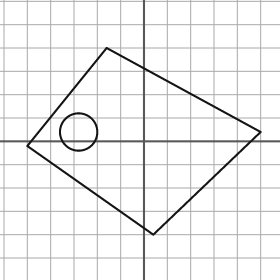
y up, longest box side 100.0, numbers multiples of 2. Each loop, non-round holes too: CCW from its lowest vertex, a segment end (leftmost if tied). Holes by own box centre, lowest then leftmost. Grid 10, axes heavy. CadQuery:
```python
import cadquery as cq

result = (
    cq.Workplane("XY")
    .moveTo(4.0, -40.0)
    .lineTo(50.0, 4.0)
    .lineTo(-16.0, 40.0)
    .lineTo(-50.0, -2.0)
    .close()
    .moveTo(-28.0, 4.0)
    .circle(8.0)
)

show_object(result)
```